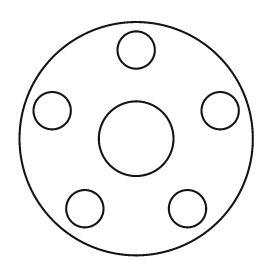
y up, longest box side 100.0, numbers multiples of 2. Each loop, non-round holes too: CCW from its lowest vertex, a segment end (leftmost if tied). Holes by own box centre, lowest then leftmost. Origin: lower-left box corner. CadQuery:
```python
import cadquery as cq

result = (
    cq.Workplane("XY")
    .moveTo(50.0, 50.0)
    .circle(50.0)
    .moveTo(28.0, 20.0)
    .circle(8.0)
    .moveTo(72.0, 20.0)
    .circle(8.0)
    .moveTo(50.0, 50.0)
    .circle(16.0)
    .moveTo(14.0, 62.0)
    .circle(8.0)
    .moveTo(86.0, 62.0)
    .circle(8.0)
    .moveTo(50.0, 88.0)
    .circle(8.0)
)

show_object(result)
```